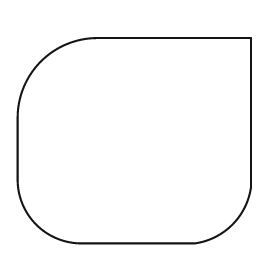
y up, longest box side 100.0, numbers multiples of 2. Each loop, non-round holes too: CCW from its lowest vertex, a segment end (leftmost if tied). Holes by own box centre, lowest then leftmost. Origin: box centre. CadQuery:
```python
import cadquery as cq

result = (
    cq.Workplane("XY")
    .moveTo(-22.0, -44.0)
    .lineTo(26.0, -44.0)
    .threePointArc((42.0, -36.0), (50.0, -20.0))
    .lineTo(50.0, 44.0)
    .lineTo(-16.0, 44.0)
    .threePointArc((-40.0, 34.0), (-50.0, 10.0))
    .lineTo(-50.0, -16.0)
    .threePointArc((-42.0, -36.0), (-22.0, -44.0))
    .close()
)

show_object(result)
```